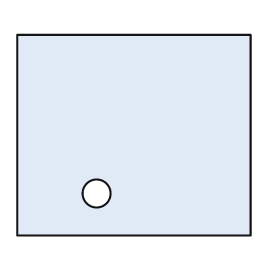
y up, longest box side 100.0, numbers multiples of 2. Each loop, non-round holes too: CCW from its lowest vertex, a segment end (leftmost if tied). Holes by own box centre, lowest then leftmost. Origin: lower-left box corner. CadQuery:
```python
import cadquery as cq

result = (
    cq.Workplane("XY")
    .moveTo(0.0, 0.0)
    .lineTo(100.0, 0.0)
    .lineTo(100.0, 86.0)
    .lineTo(0.0, 86.0)
    .close()
    .moveTo(34.0, 18.0)
    .circle(6.0)
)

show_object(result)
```